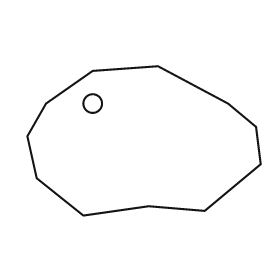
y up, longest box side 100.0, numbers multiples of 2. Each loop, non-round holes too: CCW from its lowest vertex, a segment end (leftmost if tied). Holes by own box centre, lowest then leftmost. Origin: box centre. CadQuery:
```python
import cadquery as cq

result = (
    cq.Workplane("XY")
    .moveTo(-26.0, -32.0)
    .lineTo(2.0, -28.0)
    .lineTo(26.0, -30.0)
    .lineTo(50.0, -10.0)
    .lineTo(48.0, 6.0)
    .lineTo(36.0, 16.0)
    .lineTo(6.0, 32.0)
    .lineTo(-22.0, 30.0)
    .lineTo(-42.0, 16.0)
    .lineTo(-50.0, 2.0)
    .lineTo(-46.0, -16.0)
    .close()
    .moveTo(-22.0, 16.0)
    .circle(4.0)
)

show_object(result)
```